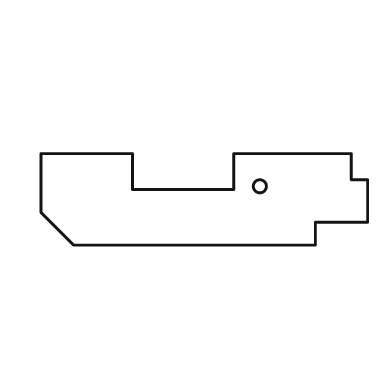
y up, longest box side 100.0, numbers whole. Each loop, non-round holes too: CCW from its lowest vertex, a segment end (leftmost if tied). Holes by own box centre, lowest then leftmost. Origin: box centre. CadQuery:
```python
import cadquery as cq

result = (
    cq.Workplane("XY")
    .moveTo(-40.0, -14.0)
    .lineTo(34.0, -14.0)
    .lineTo(34.0, -7.0)
    .lineTo(50.0, -7.0)
    .lineTo(50.0, 6.0)
    .lineTo(45.0, 6.0)
    .lineTo(45.0, 14.0)
    .lineTo(9.0, 14.0)
    .lineTo(9.0, 3.0)
    .lineTo(-22.0, 3.0)
    .lineTo(-22.0, 14.0)
    .lineTo(-50.0, 14.0)
    .lineTo(-50.0, -4.0)
    .close()
    .moveTo(17.0, 4.0)
    .circle(2.0)
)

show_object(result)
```